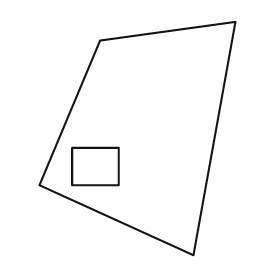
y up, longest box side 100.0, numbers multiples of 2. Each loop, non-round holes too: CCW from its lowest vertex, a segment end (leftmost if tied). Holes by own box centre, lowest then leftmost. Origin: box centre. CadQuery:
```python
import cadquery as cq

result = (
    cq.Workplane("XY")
    .moveTo(24.0, -50.0)
    .lineTo(42.0, 50.0)
    .lineTo(-16.0, 42.0)
    .lineTo(-42.0, -20.0)
    .close()
    .moveTo(-28.0, -20.0)
    .lineTo(-8.0, -20.0)
    .lineTo(-8.0, -4.0)
    .lineTo(-28.0, -4.0)
    .close()
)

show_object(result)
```